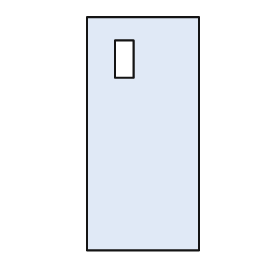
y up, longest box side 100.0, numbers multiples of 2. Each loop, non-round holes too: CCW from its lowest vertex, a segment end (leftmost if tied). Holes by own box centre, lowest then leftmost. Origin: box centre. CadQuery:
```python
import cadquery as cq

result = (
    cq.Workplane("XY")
    .moveTo(-24.0, -50.0)
    .lineTo(24.0, -50.0)
    .lineTo(24.0, 50.0)
    .lineTo(-24.0, 50.0)
    .close()
    .moveTo(-12.0, 24.0)
    .lineTo(-4.0, 24.0)
    .lineTo(-4.0, 40.0)
    .lineTo(-12.0, 40.0)
    .close()
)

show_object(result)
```